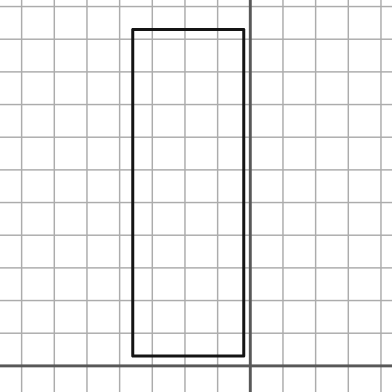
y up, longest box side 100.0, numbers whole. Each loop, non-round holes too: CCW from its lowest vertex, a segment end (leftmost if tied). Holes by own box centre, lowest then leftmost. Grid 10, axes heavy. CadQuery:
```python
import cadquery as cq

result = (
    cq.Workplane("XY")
    .moveTo(-36.0, 3.0)
    .lineTo(-2.0, 3.0)
    .lineTo(-2.0, 103.0)
    .lineTo(-36.0, 103.0)
    .close()
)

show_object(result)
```